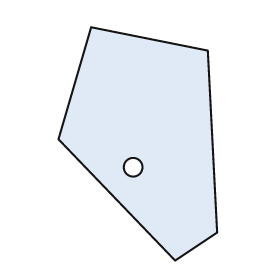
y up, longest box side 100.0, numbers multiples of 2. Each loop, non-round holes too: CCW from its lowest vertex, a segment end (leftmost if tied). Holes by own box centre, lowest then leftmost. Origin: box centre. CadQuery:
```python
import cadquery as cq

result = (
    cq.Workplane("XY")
    .moveTo(16.0, -50.0)
    .lineTo(34.0, -38.0)
    .lineTo(30.0, 40.0)
    .lineTo(-20.0, 50.0)
    .lineTo(-34.0, 2.0)
    .close()
    .moveTo(-2.0, -10.0)
    .circle(4.0)
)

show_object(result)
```